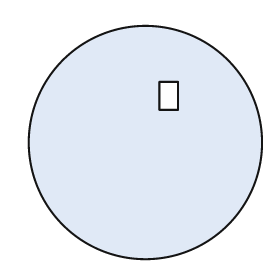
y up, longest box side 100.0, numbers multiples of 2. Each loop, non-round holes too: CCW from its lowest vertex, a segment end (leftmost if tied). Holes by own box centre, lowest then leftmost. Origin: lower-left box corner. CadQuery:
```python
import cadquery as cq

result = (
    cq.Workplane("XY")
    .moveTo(50.0, 50.0)
    .circle(50.0)
    .moveTo(56.0, 64.0)
    .lineTo(64.0, 64.0)
    .lineTo(64.0, 76.0)
    .lineTo(56.0, 76.0)
    .close()
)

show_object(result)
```